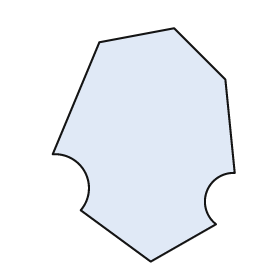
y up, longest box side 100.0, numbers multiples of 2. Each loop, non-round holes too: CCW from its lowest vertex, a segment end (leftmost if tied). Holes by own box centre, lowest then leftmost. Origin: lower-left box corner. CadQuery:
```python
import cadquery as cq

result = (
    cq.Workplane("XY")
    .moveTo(42.0, 0.0)
    .lineTo(70.0, 16.0)
    .threePointArc((66.0, 30.0), (78.0, 38.0))
    .lineTo(74.0, 78.0)
    .lineTo(52.0, 100.0)
    .lineTo(20.0, 94.0)
    .lineTo(0.0, 46.0)
    .threePointArc((14.0, 38.0), (12.0, 22.0))
    .close()
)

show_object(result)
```